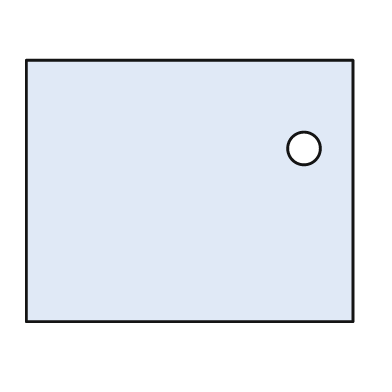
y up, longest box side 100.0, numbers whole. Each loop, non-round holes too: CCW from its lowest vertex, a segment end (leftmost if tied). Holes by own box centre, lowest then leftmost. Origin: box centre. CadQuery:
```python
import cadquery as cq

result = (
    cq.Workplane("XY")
    .moveTo(-50.0, -40.0)
    .lineTo(50.0, -40.0)
    .lineTo(50.0, 40.0)
    .lineTo(-50.0, 40.0)
    .close()
    .moveTo(35.0, 13.0)
    .circle(5.0)
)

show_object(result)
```